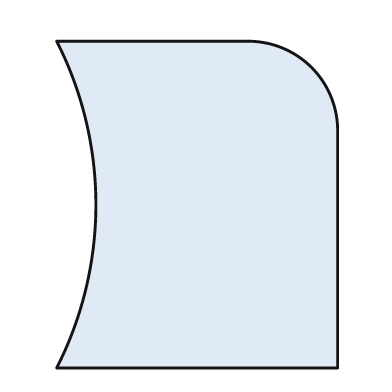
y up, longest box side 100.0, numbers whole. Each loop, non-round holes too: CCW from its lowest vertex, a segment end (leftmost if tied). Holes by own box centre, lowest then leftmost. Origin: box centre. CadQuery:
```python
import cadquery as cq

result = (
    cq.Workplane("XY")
    .moveTo(-43.0, -50.0)
    .lineTo(43.0, -50.0)
    .lineTo(43.0, 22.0)
    .threePointArc((35.0, 42.0), (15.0, 50.0))
    .lineTo(-43.0, 50.0)
    .threePointArc((-31.0, 0.0), (-43.0, -50.0))
    .close()
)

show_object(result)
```